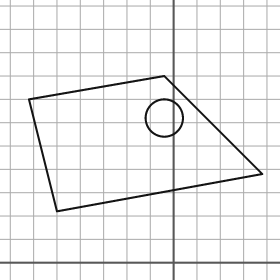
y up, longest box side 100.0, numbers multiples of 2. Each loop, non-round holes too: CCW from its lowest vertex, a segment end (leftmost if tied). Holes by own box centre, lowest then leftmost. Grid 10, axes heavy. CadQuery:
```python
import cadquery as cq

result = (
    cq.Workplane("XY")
    .moveTo(-50.0, 22.0)
    .lineTo(38.0, 38.0)
    .lineTo(-4.0, 80.0)
    .lineTo(-62.0, 70.0)
    .close()
    .moveTo(-4.0, 62.0)
    .circle(8.0)
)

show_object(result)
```